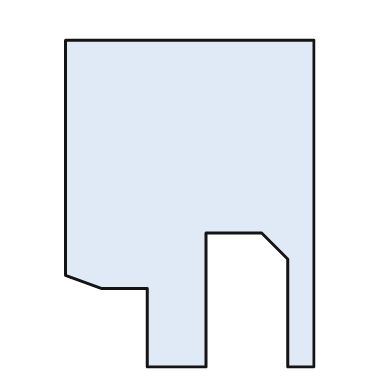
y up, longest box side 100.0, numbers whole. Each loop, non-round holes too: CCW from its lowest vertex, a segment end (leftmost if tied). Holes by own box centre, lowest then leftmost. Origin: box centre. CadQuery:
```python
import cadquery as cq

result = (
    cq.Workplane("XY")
    .moveTo(-13.0, -50.0)
    .lineTo(5.0, -50.0)
    .lineTo(5.0, -9.0)
    .lineTo(22.0, -9.0)
    .lineTo(30.0, -17.0)
    .lineTo(30.0, -50.0)
    .lineTo(38.0, -50.0)
    .lineTo(38.0, 50.0)
    .lineTo(-38.0, 50.0)
    .lineTo(-38.0, -22.0)
    .lineTo(-27.0, -26.0)
    .lineTo(-13.0, -26.0)
    .close()
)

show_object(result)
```